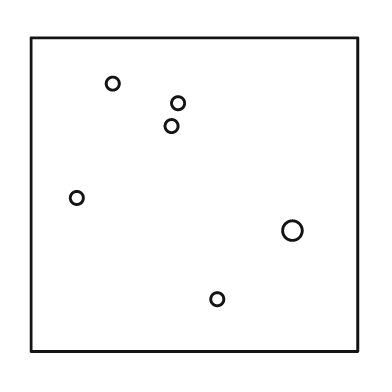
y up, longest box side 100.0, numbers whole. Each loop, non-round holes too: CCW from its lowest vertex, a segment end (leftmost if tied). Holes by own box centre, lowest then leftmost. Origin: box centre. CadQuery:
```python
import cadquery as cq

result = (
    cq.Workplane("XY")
    .moveTo(-50.0, -48.0)
    .lineTo(50.0, -48.0)
    .lineTo(50.0, 48.0)
    .lineTo(-50.0, 48.0)
    .close()
    .moveTo(7.0, -32.0)
    .circle(2.0)
    .moveTo(30.0, -11.0)
    .circle(3.0)
    .moveTo(-36.0, -1.0)
    .circle(2.0)
    .moveTo(-7.0, 21.0)
    .circle(2.0)
    .moveTo(-5.0, 28.0)
    .circle(2.0)
    .moveTo(-25.0, 34.0)
    .circle(2.0)
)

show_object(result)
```